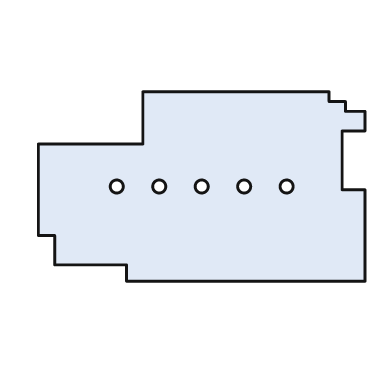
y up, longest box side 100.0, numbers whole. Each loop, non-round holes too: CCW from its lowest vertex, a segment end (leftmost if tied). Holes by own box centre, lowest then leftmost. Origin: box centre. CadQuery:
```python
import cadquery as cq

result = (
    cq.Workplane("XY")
    .moveTo(-23.0, -29.0)
    .lineTo(50.0, -29.0)
    .lineTo(50.0, -1.0)
    .lineTo(43.0, -1.0)
    .lineTo(43.0, 17.0)
    .lineTo(50.0, 17.0)
    .lineTo(50.0, 23.0)
    .lineTo(44.0, 23.0)
    .lineTo(44.0, 26.0)
    .lineTo(39.0, 26.0)
    .lineTo(39.0, 29.0)
    .lineTo(-18.0, 29.0)
    .lineTo(-18.0, 13.0)
    .lineTo(-50.0, 13.0)
    .lineTo(-50.0, -15.0)
    .lineTo(-45.0, -15.0)
    .lineTo(-45.0, -24.0)
    .lineTo(-23.0, -24.0)
    .close()
    .moveTo(-26.0, 0.0)
    .circle(2.0)
    .moveTo(-13.0, 0.0)
    .circle(2.0)
    .moveTo(0.0, 0.0)
    .circle(2.0)
    .moveTo(13.0, 0.0)
    .circle(2.0)
    .moveTo(26.0, 0.0)
    .circle(2.0)
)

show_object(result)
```